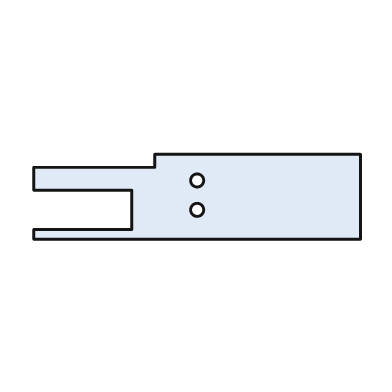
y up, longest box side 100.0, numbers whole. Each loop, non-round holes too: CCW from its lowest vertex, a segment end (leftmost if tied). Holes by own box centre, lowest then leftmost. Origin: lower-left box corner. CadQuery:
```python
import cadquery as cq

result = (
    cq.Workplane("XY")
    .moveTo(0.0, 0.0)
    .lineTo(100.0, 0.0)
    .lineTo(100.0, 26.0)
    .lineTo(37.0, 26.0)
    .lineTo(37.0, 22.0)
    .lineTo(0.0, 22.0)
    .lineTo(0.0, 15.0)
    .lineTo(30.0, 15.0)
    .lineTo(30.0, 3.0)
    .lineTo(0.0, 3.0)
    .close()
    .moveTo(50.0, 9.0)
    .circle(2.0)
    .moveTo(50.0, 18.0)
    .circle(2.0)
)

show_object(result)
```